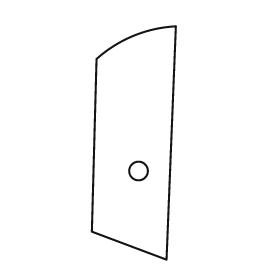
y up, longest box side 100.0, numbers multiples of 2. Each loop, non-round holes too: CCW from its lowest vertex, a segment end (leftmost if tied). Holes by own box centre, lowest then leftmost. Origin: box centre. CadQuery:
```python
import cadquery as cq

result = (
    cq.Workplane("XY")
    .moveTo(14.0, -50.0)
    .lineTo(18.0, 50.0)
    .threePointArc((0.0, 46.0), (-16.0, 36.0))
    .lineTo(-18.0, -38.0)
    .close()
    .moveTo(2.0, -12.0)
    .circle(4.0)
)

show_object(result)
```